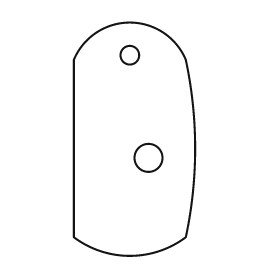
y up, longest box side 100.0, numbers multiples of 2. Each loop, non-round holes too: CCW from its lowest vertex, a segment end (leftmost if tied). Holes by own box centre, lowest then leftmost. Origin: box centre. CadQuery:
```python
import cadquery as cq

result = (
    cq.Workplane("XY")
    .moveTo(-26.0, -42.0)
    .threePointArc((-2.0, -50.0), (22.0, -42.0))
    .threePointArc((26.0, -4.0), (22.0, 34.0))
    .threePointArc((-2.0, 50.0), (-26.0, 34.0))
    .close()
    .moveTo(6.0, -8.0)
    .circle(6.0)
    .moveTo(-2.0, 36.0)
    .circle(4.0)
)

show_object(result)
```